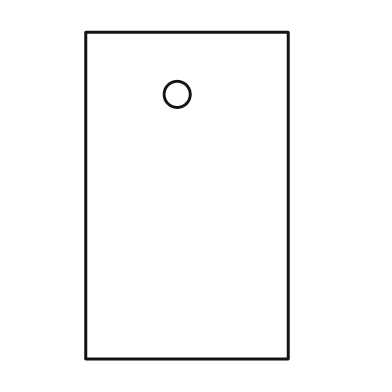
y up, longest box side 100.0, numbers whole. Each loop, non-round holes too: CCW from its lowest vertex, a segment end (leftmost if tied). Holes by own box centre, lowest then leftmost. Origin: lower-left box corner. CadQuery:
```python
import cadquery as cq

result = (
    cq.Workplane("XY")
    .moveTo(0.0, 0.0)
    .lineTo(62.0, 0.0)
    .lineTo(62.0, 100.0)
    .lineTo(0.0, 100.0)
    .close()
    .moveTo(28.0, 81.0)
    .circle(4.0)
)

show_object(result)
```